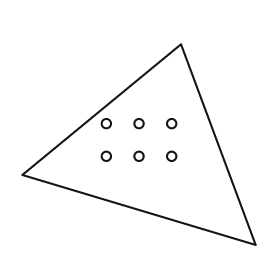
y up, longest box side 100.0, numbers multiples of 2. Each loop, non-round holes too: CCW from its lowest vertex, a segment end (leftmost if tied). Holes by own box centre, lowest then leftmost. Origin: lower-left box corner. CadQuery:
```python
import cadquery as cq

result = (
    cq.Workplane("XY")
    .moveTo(100.0, 0.0)
    .lineTo(68.0, 86.0)
    .lineTo(0.0, 30.0)
    .close()
    .moveTo(36.0, 38.0)
    .circle(2.0)
    .moveTo(50.0, 38.0)
    .circle(2.0)
    .moveTo(64.0, 38.0)
    .circle(2.0)
    .moveTo(36.0, 52.0)
    .circle(2.0)
    .moveTo(50.0, 52.0)
    .circle(2.0)
    .moveTo(64.0, 52.0)
    .circle(2.0)
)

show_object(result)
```